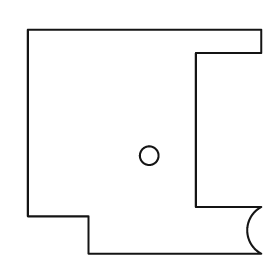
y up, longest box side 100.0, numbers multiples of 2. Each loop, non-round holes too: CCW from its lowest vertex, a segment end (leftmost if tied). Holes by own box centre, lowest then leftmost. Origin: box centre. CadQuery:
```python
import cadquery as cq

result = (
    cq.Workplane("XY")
    .moveTo(-24.0, -48.0)
    .lineTo(50.0, -48.0)
    .threePointArc((44.0, -38.0), (50.0, -28.0))
    .lineTo(22.0, -28.0)
    .lineTo(22.0, 38.0)
    .lineTo(50.0, 38.0)
    .lineTo(50.0, 48.0)
    .lineTo(-50.0, 48.0)
    .lineTo(-50.0, -32.0)
    .lineTo(-24.0, -32.0)
    .close()
    .moveTo(2.0, -6.0)
    .circle(4.0)
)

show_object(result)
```